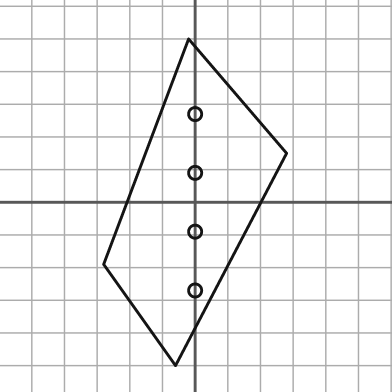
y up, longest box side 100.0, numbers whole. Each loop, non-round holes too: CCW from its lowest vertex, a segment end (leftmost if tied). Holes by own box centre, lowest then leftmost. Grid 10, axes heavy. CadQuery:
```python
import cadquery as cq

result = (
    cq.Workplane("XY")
    .moveTo(-6.0, -50.0)
    .lineTo(28.0, 15.0)
    .lineTo(-2.0, 50.0)
    .lineTo(-28.0, -19.0)
    .close()
    .moveTo(0.0, -27.0)
    .circle(2.0)
    .moveTo(0.0, -9.0)
    .circle(2.0)
    .moveTo(0.0, 9.0)
    .circle(2.0)
    .moveTo(0.0, 27.0)
    .circle(2.0)
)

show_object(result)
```